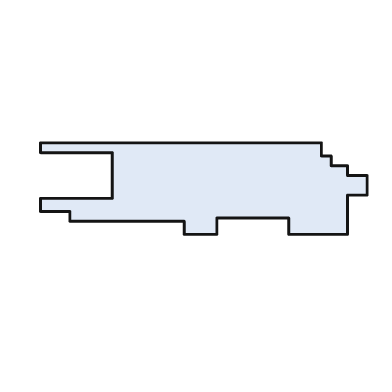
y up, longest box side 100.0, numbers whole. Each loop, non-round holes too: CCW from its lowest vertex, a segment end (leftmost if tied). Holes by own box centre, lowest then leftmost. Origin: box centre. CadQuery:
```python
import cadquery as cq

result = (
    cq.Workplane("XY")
    .moveTo(-6.0, -14.0)
    .lineTo(4.0, -14.0)
    .lineTo(4.0, -9.0)
    .lineTo(26.0, -9.0)
    .lineTo(26.0, -14.0)
    .lineTo(44.0, -14.0)
    .lineTo(44.0, -2.0)
    .lineTo(50.0, -2.0)
    .lineTo(50.0, 4.0)
    .lineTo(44.0, 4.0)
    .lineTo(44.0, 7.0)
    .lineTo(39.0, 7.0)
    .lineTo(39.0, 10.0)
    .lineTo(36.0, 10.0)
    .lineTo(36.0, 14.0)
    .lineTo(-50.0, 14.0)
    .lineTo(-50.0, 11.0)
    .lineTo(-28.0, 11.0)
    .lineTo(-28.0, -3.0)
    .lineTo(-50.0, -3.0)
    .lineTo(-50.0, -7.0)
    .lineTo(-41.0, -7.0)
    .lineTo(-41.0, -10.0)
    .lineTo(-6.0, -10.0)
    .close()
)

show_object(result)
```